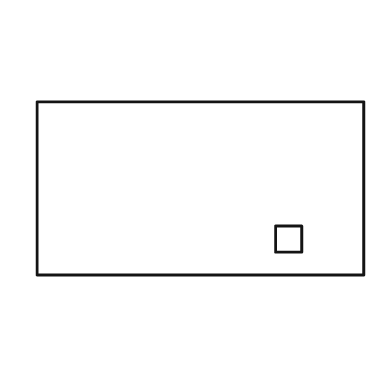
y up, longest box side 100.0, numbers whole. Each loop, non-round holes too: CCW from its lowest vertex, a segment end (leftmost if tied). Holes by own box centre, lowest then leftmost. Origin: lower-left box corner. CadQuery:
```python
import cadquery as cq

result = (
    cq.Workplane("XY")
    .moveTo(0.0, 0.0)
    .lineTo(100.0, 0.0)
    .lineTo(100.0, 53.0)
    .lineTo(0.0, 53.0)
    .close()
    .moveTo(73.0, 7.0)
    .lineTo(81.0, 7.0)
    .lineTo(81.0, 15.0)
    .lineTo(73.0, 15.0)
    .close()
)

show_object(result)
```